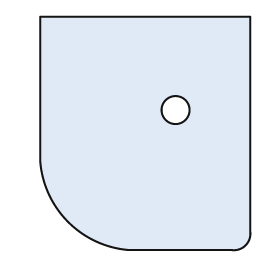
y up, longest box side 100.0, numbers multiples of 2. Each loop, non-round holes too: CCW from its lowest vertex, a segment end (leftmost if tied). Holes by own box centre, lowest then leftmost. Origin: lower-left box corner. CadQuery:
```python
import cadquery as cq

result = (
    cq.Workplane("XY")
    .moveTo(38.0, 0.0)
    .lineTo(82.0, 0.0)
    .threePointArc((88.0, 2.0), (90.0, 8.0))
    .lineTo(90.0, 100.0)
    .lineTo(0.0, 100.0)
    .lineTo(0.0, 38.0)
    .threePointArc((12.0, 12.0), (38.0, 0.0))
    .close()
    .moveTo(58.0, 60.0)
    .circle(6.0)
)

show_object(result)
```